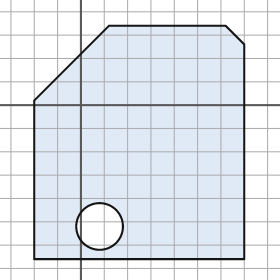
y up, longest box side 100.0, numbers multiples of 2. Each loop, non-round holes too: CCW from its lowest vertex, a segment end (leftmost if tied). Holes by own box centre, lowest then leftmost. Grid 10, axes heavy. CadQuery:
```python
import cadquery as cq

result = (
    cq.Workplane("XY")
    .moveTo(-20.0, -66.0)
    .lineTo(70.0, -66.0)
    .lineTo(70.0, 26.0)
    .lineTo(62.0, 34.0)
    .lineTo(12.0, 34.0)
    .lineTo(-20.0, 2.0)
    .close()
    .moveTo(8.0, -52.0)
    .circle(10.0)
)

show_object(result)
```